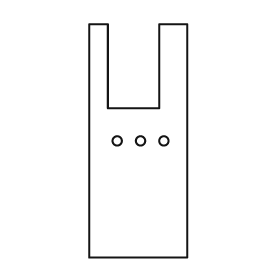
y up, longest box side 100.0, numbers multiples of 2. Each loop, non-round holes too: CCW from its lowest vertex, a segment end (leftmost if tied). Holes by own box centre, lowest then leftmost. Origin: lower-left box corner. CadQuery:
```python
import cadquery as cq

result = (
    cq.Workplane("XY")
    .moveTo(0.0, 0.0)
    .lineTo(42.0, 0.0)
    .lineTo(42.0, 100.0)
    .lineTo(30.0, 100.0)
    .lineTo(30.0, 64.0)
    .lineTo(8.0, 64.0)
    .lineTo(8.0, 100.0)
    .lineTo(0.0, 100.0)
    .close()
    .moveTo(12.0, 50.0)
    .circle(2.0)
    .moveTo(22.0, 50.0)
    .circle(2.0)
    .moveTo(32.0, 50.0)
    .circle(2.0)
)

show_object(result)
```